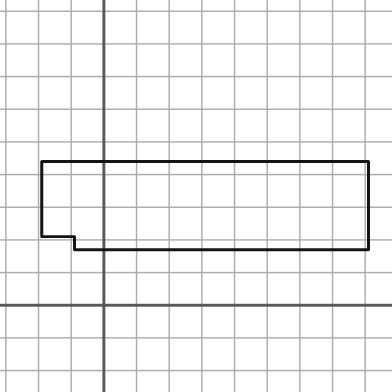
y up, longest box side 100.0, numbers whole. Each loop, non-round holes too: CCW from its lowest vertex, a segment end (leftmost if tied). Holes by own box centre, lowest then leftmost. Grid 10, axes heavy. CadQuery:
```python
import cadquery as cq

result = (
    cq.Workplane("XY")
    .moveTo(-9.0, 17.0)
    .lineTo(81.0, 17.0)
    .lineTo(81.0, 44.0)
    .lineTo(-19.0, 44.0)
    .lineTo(-19.0, 21.0)
    .lineTo(-9.0, 21.0)
    .close()
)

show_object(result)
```